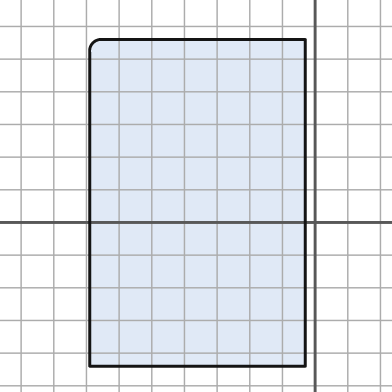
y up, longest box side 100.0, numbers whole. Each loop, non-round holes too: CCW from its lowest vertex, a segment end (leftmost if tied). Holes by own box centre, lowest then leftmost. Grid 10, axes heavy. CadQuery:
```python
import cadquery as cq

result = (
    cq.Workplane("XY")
    .moveTo(-69.0, -44.0)
    .lineTo(-3.0, -44.0)
    .lineTo(-3.0, 56.0)
    .lineTo(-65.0, 56.0)
    .threePointArc((-68.0, 55.0), (-69.0, 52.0))
    .close()
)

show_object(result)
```